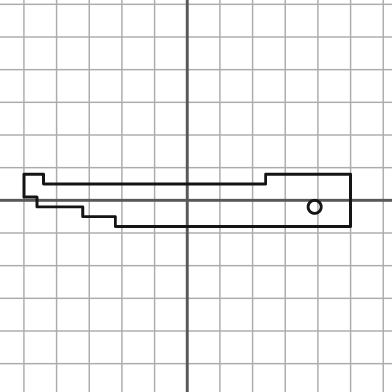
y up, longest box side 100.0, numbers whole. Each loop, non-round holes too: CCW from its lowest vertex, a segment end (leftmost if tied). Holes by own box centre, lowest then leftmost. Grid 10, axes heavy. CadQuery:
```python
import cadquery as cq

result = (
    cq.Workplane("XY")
    .moveTo(-22.0, -8.0)
    .lineTo(50.0, -8.0)
    .lineTo(50.0, 8.0)
    .lineTo(24.0, 8.0)
    .lineTo(24.0, 5.0)
    .lineTo(-44.0, 5.0)
    .lineTo(-44.0, 8.0)
    .lineTo(-50.0, 8.0)
    .lineTo(-50.0, 1.0)
    .lineTo(-46.0, 1.0)
    .lineTo(-46.0, -2.0)
    .lineTo(-32.0, -2.0)
    .lineTo(-32.0, -5.0)
    .lineTo(-22.0, -5.0)
    .close()
    .moveTo(39.0, -2.0)
    .circle(2.0)
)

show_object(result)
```